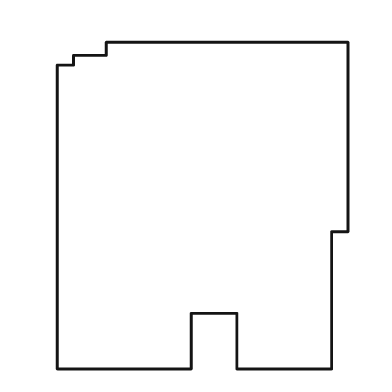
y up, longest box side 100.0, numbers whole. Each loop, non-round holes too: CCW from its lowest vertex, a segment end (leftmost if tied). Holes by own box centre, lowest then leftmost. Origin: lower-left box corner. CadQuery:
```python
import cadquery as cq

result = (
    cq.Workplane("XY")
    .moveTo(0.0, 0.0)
    .lineTo(41.0, 0.0)
    .lineTo(41.0, 17.0)
    .lineTo(55.0, 17.0)
    .lineTo(55.0, 0.0)
    .lineTo(84.0, 0.0)
    .lineTo(84.0, 42.0)
    .lineTo(89.0, 42.0)
    .lineTo(89.0, 100.0)
    .lineTo(15.0, 100.0)
    .lineTo(15.0, 96.0)
    .lineTo(5.0, 96.0)
    .lineTo(5.0, 93.0)
    .lineTo(0.0, 93.0)
    .close()
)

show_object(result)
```